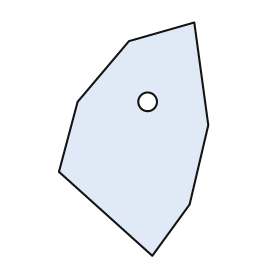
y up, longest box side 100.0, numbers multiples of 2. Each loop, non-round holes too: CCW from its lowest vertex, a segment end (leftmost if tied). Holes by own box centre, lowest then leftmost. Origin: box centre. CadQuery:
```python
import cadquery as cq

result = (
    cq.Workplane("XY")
    .moveTo(8.0, -50.0)
    .lineTo(24.0, -28.0)
    .lineTo(32.0, 6.0)
    .lineTo(26.0, 50.0)
    .lineTo(-2.0, 42.0)
    .lineTo(-24.0, 16.0)
    .lineTo(-32.0, -14.0)
    .close()
    .moveTo(6.0, 16.0)
    .circle(4.0)
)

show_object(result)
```